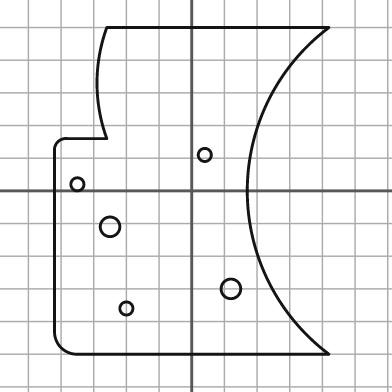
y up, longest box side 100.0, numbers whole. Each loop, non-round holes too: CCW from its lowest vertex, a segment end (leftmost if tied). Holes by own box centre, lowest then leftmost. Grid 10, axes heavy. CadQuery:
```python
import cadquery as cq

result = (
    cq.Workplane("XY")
    .moveTo(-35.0, -50.0)
    .lineTo(42.0, -50.0)
    .threePointArc((17.0, 0.0), (42.0, 50.0))
    .lineTo(-26.0, 50.0)
    .threePointArc((-29.0, 33.0), (-26.0, 16.0))
    .lineTo(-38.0, 16.0)
    .threePointArc((-41.0, 15.0), (-42.0, 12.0))
    .lineTo(-42.0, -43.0)
    .threePointArc((-40.0, -48.0), (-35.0, -50.0))
    .close()
    .moveTo(-20.0, -36.0)
    .circle(2.0)
    .moveTo(12.0, -30.0)
    .circle(3.0)
    .moveTo(-25.0, -11.0)
    .circle(3.0)
    .moveTo(-35.0, 2.0)
    .circle(2.0)
    .moveTo(4.0, 11.0)
    .circle(2.0)
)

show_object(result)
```